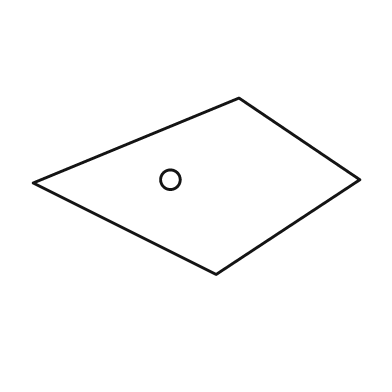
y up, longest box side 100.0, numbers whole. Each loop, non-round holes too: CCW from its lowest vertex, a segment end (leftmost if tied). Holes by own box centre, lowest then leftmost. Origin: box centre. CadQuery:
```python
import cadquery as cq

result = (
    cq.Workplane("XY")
    .moveTo(6.0, -27.0)
    .lineTo(50.0, 2.0)
    .lineTo(13.0, 27.0)
    .lineTo(-50.0, 1.0)
    .close()
    .moveTo(-8.0, 2.0)
    .circle(3.0)
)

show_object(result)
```